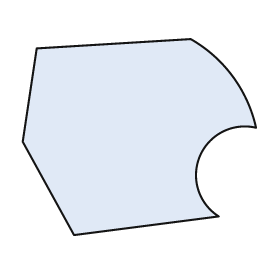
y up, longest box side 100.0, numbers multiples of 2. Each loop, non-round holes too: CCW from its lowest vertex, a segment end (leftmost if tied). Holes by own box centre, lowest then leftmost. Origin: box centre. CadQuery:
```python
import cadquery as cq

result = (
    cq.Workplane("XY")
    .moveTo(-28.0, -42.0)
    .lineTo(34.0, -34.0)
    .threePointArc((26.0, -8.0), (50.0, 4.0))
    .threePointArc((40.0, 26.0), (22.0, 42.0))
    .lineTo(-44.0, 38.0)
    .lineTo(-50.0, -2.0)
    .close()
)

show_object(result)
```